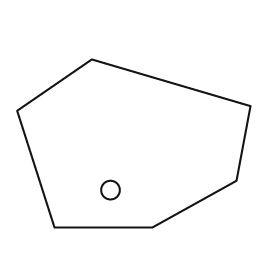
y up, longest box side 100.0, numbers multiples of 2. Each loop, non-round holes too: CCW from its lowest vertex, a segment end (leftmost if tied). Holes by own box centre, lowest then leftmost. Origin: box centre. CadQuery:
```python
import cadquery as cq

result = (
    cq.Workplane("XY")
    .moveTo(-34.0, -36.0)
    .lineTo(8.0, -36.0)
    .lineTo(44.0, -16.0)
    .lineTo(50.0, 16.0)
    .lineTo(-18.0, 36.0)
    .lineTo(-50.0, 14.0)
    .close()
    .moveTo(-10.0, -20.0)
    .circle(4.0)
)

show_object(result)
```